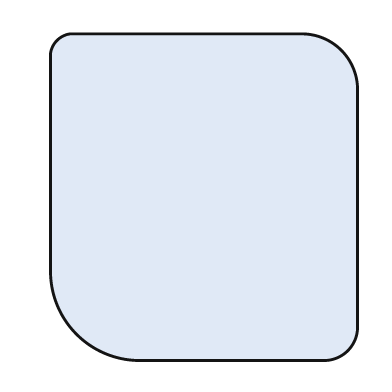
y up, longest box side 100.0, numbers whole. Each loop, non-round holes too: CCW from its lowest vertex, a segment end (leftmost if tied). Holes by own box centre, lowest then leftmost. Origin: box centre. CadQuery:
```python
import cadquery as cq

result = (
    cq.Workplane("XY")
    .moveTo(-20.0, -50.0)
    .lineTo(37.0, -50.0)
    .threePointArc((44.0, -47.0), (47.0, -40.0))
    .lineTo(47.0, 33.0)
    .threePointArc((42.0, 45.0), (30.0, 50.0))
    .lineTo(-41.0, 50.0)
    .threePointArc((-45.0, 48.0), (-47.0, 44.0))
    .lineTo(-47.0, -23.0)
    .threePointArc((-39.0, -42.0), (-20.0, -50.0))
    .close()
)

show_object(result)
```